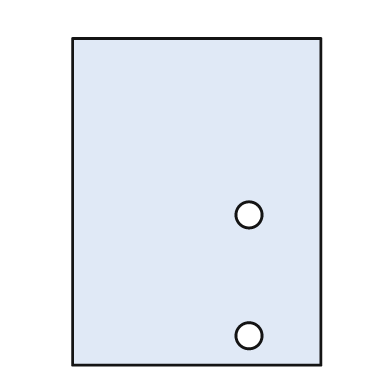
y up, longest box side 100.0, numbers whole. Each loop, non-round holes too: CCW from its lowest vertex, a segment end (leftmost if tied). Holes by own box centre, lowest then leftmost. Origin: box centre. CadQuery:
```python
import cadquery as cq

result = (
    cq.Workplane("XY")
    .moveTo(-38.0, -50.0)
    .lineTo(38.0, -50.0)
    .lineTo(38.0, 50.0)
    .lineTo(-38.0, 50.0)
    .close()
    .moveTo(16.0, -41.0)
    .circle(4.0)
    .moveTo(16.0, -4.0)
    .circle(4.0)
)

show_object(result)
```